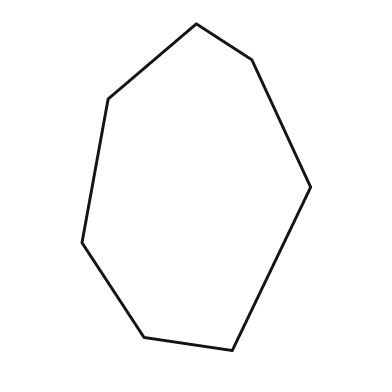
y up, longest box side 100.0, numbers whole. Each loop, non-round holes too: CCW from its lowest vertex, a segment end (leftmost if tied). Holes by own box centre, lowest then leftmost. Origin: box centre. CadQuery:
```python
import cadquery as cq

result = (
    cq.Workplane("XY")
    .moveTo(11.0, -50.0)
    .lineTo(35.0, 0.0)
    .lineTo(17.0, 39.0)
    .lineTo(0.0, 50.0)
    .lineTo(-27.0, 27.0)
    .lineTo(-35.0, -17.0)
    .lineTo(-16.0, -46.0)
    .close()
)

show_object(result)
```